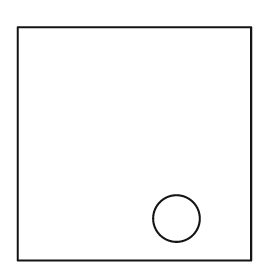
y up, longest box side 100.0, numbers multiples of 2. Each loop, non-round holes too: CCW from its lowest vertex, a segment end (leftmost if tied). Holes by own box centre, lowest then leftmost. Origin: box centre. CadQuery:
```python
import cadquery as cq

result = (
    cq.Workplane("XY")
    .moveTo(-50.0, -50.0)
    .lineTo(50.0, -50.0)
    .lineTo(50.0, 50.0)
    .lineTo(-50.0, 50.0)
    .close()
    .moveTo(18.0, -32.0)
    .circle(10.0)
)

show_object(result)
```